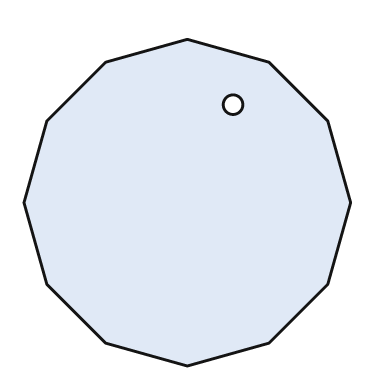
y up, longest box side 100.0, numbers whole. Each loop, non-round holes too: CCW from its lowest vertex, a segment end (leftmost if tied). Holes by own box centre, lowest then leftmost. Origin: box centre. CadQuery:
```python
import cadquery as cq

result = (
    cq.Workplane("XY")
    .moveTo(0.0, -50.0)
    .lineTo(25.0, -43.0)
    .lineTo(43.0, -25.0)
    .lineTo(50.0, 0.0)
    .lineTo(43.0, 25.0)
    .lineTo(25.0, 43.0)
    .lineTo(0.0, 50.0)
    .lineTo(-25.0, 43.0)
    .lineTo(-43.0, 25.0)
    .lineTo(-50.0, 0.0)
    .lineTo(-43.0, -25.0)
    .lineTo(-25.0, -43.0)
    .close()
    .moveTo(14.0, 30.0)
    .circle(3.0)
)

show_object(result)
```